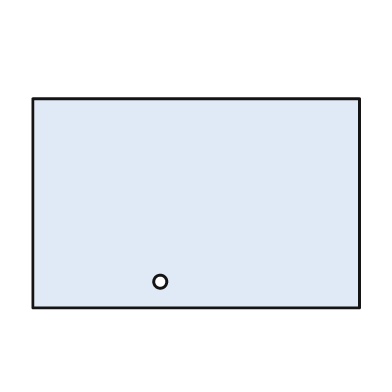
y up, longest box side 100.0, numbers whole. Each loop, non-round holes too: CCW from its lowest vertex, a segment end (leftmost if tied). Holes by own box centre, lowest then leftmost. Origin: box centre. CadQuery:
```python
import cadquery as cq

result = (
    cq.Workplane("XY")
    .moveTo(-50.0, -32.0)
    .lineTo(50.0, -32.0)
    .lineTo(50.0, 32.0)
    .lineTo(-50.0, 32.0)
    .close()
    .moveTo(-11.0, -24.0)
    .circle(2.0)
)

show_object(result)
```